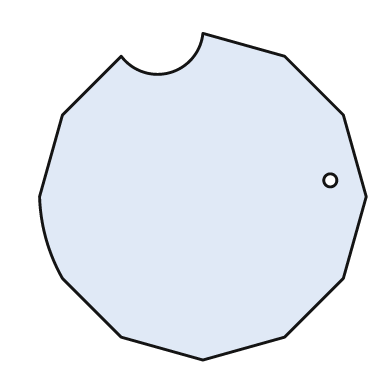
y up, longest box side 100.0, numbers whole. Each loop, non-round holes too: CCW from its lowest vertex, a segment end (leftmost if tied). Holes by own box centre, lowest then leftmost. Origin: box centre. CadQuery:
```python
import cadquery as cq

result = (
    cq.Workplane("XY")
    .moveTo(0.0, -50.0)
    .lineTo(25.0, -43.0)
    .lineTo(43.0, -25.0)
    .lineTo(50.0, 0.0)
    .lineTo(43.0, 25.0)
    .lineTo(25.0, 43.0)
    .lineTo(0.0, 50.0)
    .threePointArc((-10.0, 38.0), (-25.0, 43.0))
    .lineTo(-43.0, 25.0)
    .lineTo(-50.0, 0.0)
    .threePointArc((-48.0, -13.0), (-43.0, -25.0))
    .lineTo(-25.0, -43.0)
    .close()
    .moveTo(39.0, 5.0)
    .circle(2.0)
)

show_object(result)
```